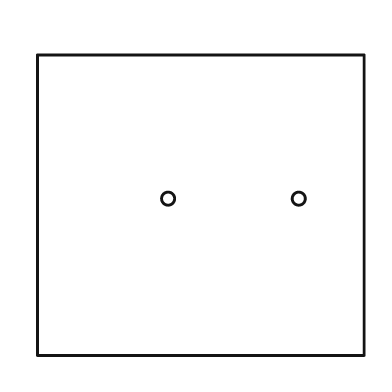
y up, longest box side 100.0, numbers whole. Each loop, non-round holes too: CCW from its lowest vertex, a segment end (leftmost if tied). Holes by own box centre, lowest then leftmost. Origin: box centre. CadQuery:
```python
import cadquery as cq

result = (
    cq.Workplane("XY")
    .moveTo(-50.0, -46.0)
    .lineTo(50.0, -46.0)
    .lineTo(50.0, 46.0)
    .lineTo(-50.0, 46.0)
    .close()
    .moveTo(-10.0, 2.0)
    .circle(2.0)
    .moveTo(30.0, 2.0)
    .circle(2.0)
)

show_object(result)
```